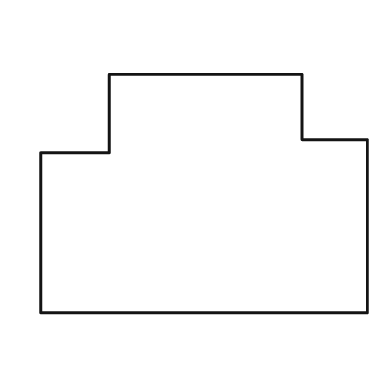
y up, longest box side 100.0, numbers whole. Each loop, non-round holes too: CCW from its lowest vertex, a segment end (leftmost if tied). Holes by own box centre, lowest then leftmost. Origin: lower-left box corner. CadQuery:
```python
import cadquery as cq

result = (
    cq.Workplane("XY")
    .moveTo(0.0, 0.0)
    .lineTo(100.0, 0.0)
    .lineTo(100.0, 53.0)
    .lineTo(80.0, 53.0)
    .lineTo(80.0, 73.0)
    .lineTo(21.0, 73.0)
    .lineTo(21.0, 49.0)
    .lineTo(0.0, 49.0)
    .close()
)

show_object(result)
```